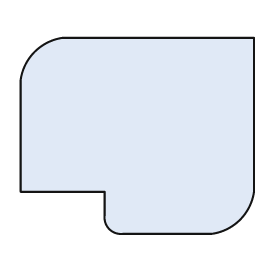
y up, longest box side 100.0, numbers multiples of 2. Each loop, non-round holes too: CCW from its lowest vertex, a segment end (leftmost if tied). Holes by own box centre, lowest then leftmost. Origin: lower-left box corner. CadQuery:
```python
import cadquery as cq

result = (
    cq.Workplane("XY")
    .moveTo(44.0, 0.0)
    .lineTo(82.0, 0.0)
    .threePointArc((94.0, 6.0), (100.0, 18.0))
    .lineTo(100.0, 84.0)
    .lineTo(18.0, 84.0)
    .threePointArc((6.0, 78.0), (0.0, 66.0))
    .lineTo(0.0, 18.0)
    .lineTo(36.0, 18.0)
    .lineTo(36.0, 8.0)
    .threePointArc((38.0, 2.0), (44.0, 0.0))
    .close()
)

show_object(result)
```